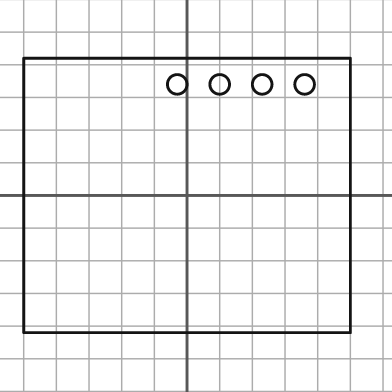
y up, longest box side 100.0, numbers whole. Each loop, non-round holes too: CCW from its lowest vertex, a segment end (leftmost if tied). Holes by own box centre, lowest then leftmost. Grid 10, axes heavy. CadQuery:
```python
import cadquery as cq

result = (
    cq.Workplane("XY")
    .moveTo(-50.0, -42.0)
    .lineTo(50.0, -42.0)
    .lineTo(50.0, 42.0)
    .lineTo(-50.0, 42.0)
    .close()
    .moveTo(-3.0, 34.0)
    .circle(3.0)
    .moveTo(10.0, 34.0)
    .circle(3.0)
    .moveTo(23.0, 34.0)
    .circle(3.0)
    .moveTo(36.0, 34.0)
    .circle(3.0)
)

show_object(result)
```